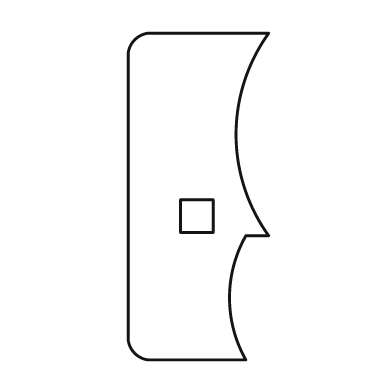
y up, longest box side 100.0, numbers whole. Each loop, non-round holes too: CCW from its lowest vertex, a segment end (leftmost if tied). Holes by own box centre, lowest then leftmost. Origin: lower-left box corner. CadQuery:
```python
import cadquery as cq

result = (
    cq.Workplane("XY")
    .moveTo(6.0, 0.0)
    .lineTo(36.0, 0.0)
    .threePointArc((31.0, 19.0), (36.0, 38.0))
    .lineTo(43.0, 38.0)
    .threePointArc((33.0, 69.0), (43.0, 100.0))
    .lineTo(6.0, 100.0)
    .threePointArc((2.0, 98.0), (0.0, 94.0))
    .lineTo(0.0, 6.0)
    .threePointArc((2.0, 2.0), (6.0, 0.0))
    .close()
    .moveTo(16.0, 39.0)
    .lineTo(26.0, 39.0)
    .lineTo(26.0, 49.0)
    .lineTo(16.0, 49.0)
    .close()
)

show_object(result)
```